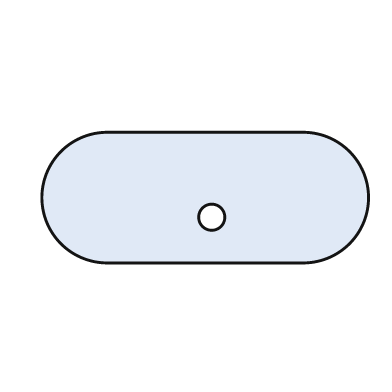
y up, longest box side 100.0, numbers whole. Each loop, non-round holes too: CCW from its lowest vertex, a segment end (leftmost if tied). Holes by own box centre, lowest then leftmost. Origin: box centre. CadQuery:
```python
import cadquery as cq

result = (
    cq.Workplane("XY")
    .moveTo(-30.0, -20.0)
    .lineTo(30.0, -20.0)
    .threePointArc((50.0, 0.0), (30.0, 20.0))
    .lineTo(-30.0, 20.0)
    .threePointArc((-50.0, 0.0), (-30.0, -20.0))
    .close()
    .moveTo(2.0, -6.0)
    .circle(4.0)
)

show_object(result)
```